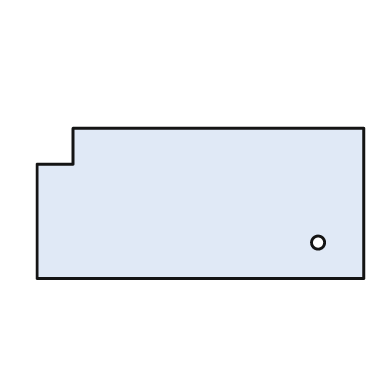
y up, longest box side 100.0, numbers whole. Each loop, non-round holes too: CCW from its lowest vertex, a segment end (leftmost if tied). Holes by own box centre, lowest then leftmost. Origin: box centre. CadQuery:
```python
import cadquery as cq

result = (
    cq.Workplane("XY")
    .moveTo(-50.0, -23.0)
    .lineTo(50.0, -23.0)
    .lineTo(50.0, 23.0)
    .lineTo(-39.0, 23.0)
    .lineTo(-39.0, 12.0)
    .lineTo(-50.0, 12.0)
    .close()
    .moveTo(36.0, -12.0)
    .circle(2.0)
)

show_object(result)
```